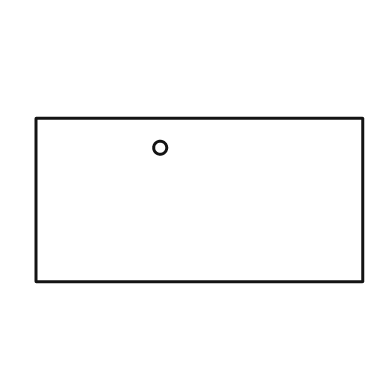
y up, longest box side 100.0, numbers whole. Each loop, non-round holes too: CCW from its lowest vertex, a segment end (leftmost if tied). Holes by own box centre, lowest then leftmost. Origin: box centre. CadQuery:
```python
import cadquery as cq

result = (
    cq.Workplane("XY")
    .moveTo(-50.0, -25.0)
    .lineTo(50.0, -25.0)
    .lineTo(50.0, 25.0)
    .lineTo(-50.0, 25.0)
    .close()
    .moveTo(-12.0, 16.0)
    .circle(2.0)
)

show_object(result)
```